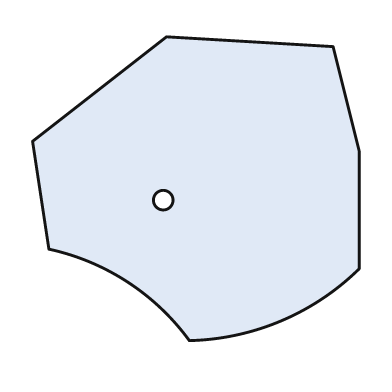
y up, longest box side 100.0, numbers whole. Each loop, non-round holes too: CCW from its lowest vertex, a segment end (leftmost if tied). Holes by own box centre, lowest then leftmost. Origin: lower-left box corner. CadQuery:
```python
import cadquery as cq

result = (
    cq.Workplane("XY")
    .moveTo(48.0, 0.0)
    .threePointArc((76.0, 6.0), (100.0, 22.0))
    .lineTo(100.0, 58.0)
    .lineTo(92.0, 90.0)
    .lineTo(41.0, 93.0)
    .lineTo(0.0, 61.0)
    .lineTo(5.0, 28.0)
    .threePointArc((29.0, 18.0), (48.0, 0.0))
    .close()
    .moveTo(40.0, 43.0)
    .circle(3.0)
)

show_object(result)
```